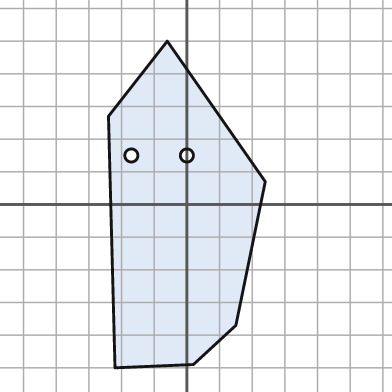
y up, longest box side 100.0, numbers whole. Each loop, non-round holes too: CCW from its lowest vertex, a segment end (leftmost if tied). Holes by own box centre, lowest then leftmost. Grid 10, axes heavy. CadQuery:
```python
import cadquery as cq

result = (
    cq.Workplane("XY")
    .moveTo(-22.0, -50.0)
    .lineTo(2.0, -49.0)
    .lineTo(15.0, -37.0)
    .lineTo(24.0, 7.0)
    .lineTo(-6.0, 50.0)
    .lineTo(-24.0, 27.0)
    .close()
    .moveTo(-17.0, 15.0)
    .circle(2.0)
    .moveTo(0.0, 15.0)
    .circle(2.0)
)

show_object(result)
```